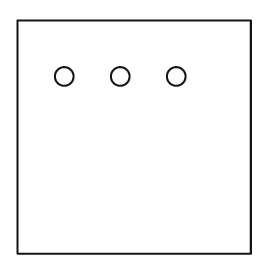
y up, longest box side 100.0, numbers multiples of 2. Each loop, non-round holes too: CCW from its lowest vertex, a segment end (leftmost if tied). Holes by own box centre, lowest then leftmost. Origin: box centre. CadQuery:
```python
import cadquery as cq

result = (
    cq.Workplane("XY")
    .moveTo(-50.0, -50.0)
    .lineTo(50.0, -50.0)
    .lineTo(50.0, 50.0)
    .lineTo(-50.0, 50.0)
    .close()
    .moveTo(-30.0, 26.0)
    .circle(4.0)
    .moveTo(-6.0, 26.0)
    .circle(4.0)
    .moveTo(18.0, 26.0)
    .circle(4.0)
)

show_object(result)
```